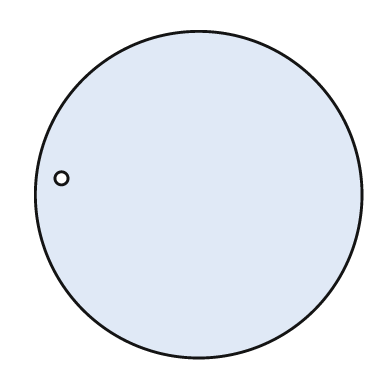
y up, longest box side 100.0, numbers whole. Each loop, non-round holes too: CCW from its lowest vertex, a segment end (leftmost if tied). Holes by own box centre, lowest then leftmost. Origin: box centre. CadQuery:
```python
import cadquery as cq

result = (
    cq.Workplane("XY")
    .moveTo(0.0, 0.0)
    .circle(50.0)
    .moveTo(-42.0, 5.0)
    .circle(2.0)
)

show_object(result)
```